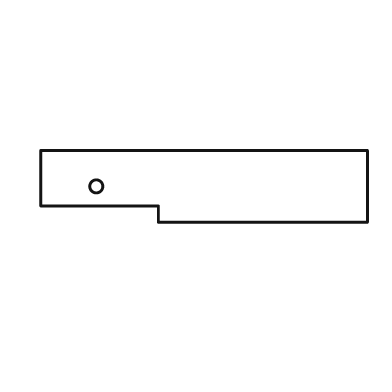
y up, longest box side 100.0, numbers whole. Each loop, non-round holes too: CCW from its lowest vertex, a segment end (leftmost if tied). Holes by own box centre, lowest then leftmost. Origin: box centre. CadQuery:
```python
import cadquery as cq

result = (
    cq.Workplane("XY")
    .moveTo(-14.0, -11.0)
    .lineTo(50.0, -11.0)
    .lineTo(50.0, 11.0)
    .lineTo(-50.0, 11.0)
    .lineTo(-50.0, -6.0)
    .lineTo(-14.0, -6.0)
    .close()
    .moveTo(-33.0, 0.0)
    .circle(2.0)
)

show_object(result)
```